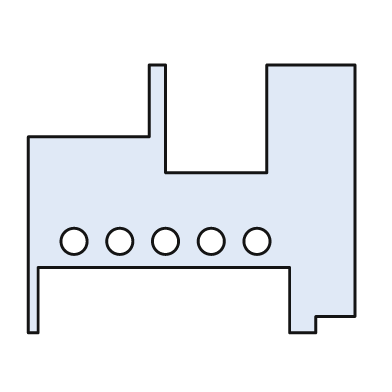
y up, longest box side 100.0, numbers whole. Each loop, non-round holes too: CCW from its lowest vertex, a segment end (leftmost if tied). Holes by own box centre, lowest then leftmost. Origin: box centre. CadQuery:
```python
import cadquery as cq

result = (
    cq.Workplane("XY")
    .moveTo(-50.0, -41.0)
    .lineTo(-47.0, -41.0)
    .lineTo(-47.0, -21.0)
    .lineTo(30.0, -21.0)
    .lineTo(30.0, -41.0)
    .lineTo(38.0, -41.0)
    .lineTo(38.0, -36.0)
    .lineTo(50.0, -36.0)
    .lineTo(50.0, 41.0)
    .lineTo(23.0, 41.0)
    .lineTo(23.0, 8.0)
    .lineTo(-8.0, 8.0)
    .lineTo(-8.0, 41.0)
    .lineTo(-13.0, 41.0)
    .lineTo(-13.0, 19.0)
    .lineTo(-50.0, 19.0)
    .close()
    .moveTo(-36.0, -13.0)
    .circle(4.0)
    .moveTo(-22.0, -13.0)
    .circle(4.0)
    .moveTo(-8.0, -13.0)
    .circle(4.0)
    .moveTo(6.0, -13.0)
    .circle(4.0)
    .moveTo(20.0, -13.0)
    .circle(4.0)
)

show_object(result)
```